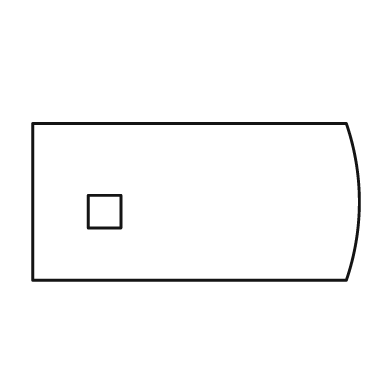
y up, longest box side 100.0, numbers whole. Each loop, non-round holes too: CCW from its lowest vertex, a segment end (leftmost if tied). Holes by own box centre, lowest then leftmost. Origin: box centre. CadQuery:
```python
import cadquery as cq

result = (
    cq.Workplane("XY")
    .moveTo(-50.0, -24.0)
    .lineTo(46.0, -24.0)
    .threePointArc((50.0, 0.0), (46.0, 24.0))
    .lineTo(-50.0, 24.0)
    .close()
    .moveTo(-33.0, -8.0)
    .lineTo(-23.0, -8.0)
    .lineTo(-23.0, 2.0)
    .lineTo(-33.0, 2.0)
    .close()
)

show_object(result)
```